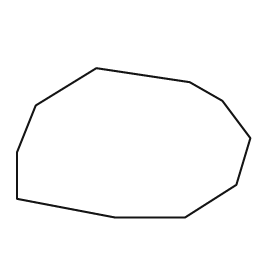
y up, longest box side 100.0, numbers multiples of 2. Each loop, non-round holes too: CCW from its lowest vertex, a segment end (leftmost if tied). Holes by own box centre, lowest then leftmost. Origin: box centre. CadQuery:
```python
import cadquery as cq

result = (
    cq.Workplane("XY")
    .moveTo(-8.0, -32.0)
    .lineTo(22.0, -32.0)
    .lineTo(44.0, -18.0)
    .lineTo(50.0, 2.0)
    .lineTo(38.0, 18.0)
    .lineTo(24.0, 26.0)
    .lineTo(-16.0, 32.0)
    .lineTo(-42.0, 16.0)
    .lineTo(-50.0, -4.0)
    .lineTo(-50.0, -24.0)
    .close()
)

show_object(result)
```